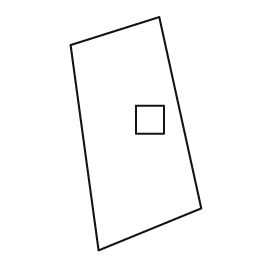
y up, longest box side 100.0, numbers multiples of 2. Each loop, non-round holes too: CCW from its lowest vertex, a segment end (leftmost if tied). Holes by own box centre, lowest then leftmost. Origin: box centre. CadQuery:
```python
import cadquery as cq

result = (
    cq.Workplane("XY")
    .moveTo(-16.0, -50.0)
    .lineTo(28.0, -32.0)
    .lineTo(10.0, 50.0)
    .lineTo(-28.0, 38.0)
    .close()
    .moveTo(0.0, 0.0)
    .lineTo(12.0, 0.0)
    .lineTo(12.0, 12.0)
    .lineTo(0.0, 12.0)
    .close()
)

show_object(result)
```